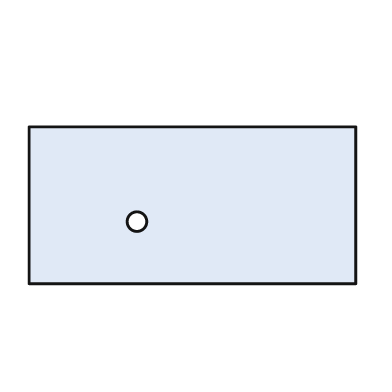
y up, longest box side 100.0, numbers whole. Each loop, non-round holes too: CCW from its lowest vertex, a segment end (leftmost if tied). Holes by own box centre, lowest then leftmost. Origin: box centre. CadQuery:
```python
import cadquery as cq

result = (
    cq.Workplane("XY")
    .moveTo(-50.0, -24.0)
    .lineTo(50.0, -24.0)
    .lineTo(50.0, 24.0)
    .lineTo(-50.0, 24.0)
    .close()
    .moveTo(-17.0, -5.0)
    .circle(3.0)
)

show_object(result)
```